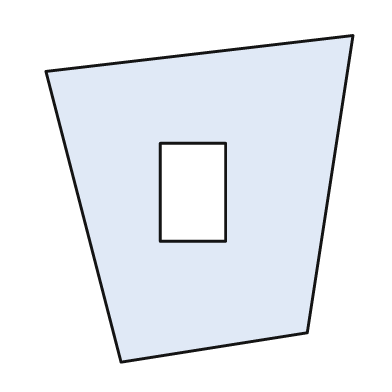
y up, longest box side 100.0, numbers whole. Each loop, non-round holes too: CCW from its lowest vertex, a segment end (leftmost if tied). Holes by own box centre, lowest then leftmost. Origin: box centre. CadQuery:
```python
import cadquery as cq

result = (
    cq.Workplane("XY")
    .moveTo(-24.0, -50.0)
    .lineTo(33.0, -41.0)
    .lineTo(47.0, 50.0)
    .lineTo(-47.0, 39.0)
    .close()
    .moveTo(-12.0, -13.0)
    .lineTo(8.0, -13.0)
    .lineTo(8.0, 17.0)
    .lineTo(-12.0, 17.0)
    .close()
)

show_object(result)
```